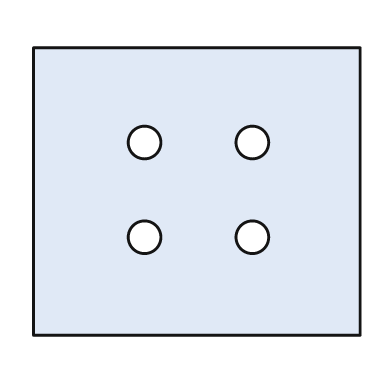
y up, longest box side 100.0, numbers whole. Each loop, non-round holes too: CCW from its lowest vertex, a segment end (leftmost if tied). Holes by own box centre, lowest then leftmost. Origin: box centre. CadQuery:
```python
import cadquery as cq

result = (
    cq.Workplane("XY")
    .moveTo(-50.0, -44.0)
    .lineTo(50.0, -44.0)
    .lineTo(50.0, 44.0)
    .lineTo(-50.0, 44.0)
    .close()
    .moveTo(-16.0, -14.0)
    .circle(5.0)
    .moveTo(17.0, -14.0)
    .circle(5.0)
    .moveTo(-16.0, 15.0)
    .circle(5.0)
    .moveTo(17.0, 15.0)
    .circle(5.0)
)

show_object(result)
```